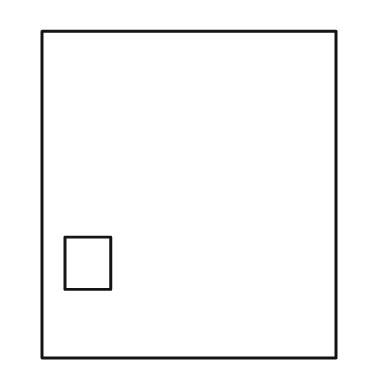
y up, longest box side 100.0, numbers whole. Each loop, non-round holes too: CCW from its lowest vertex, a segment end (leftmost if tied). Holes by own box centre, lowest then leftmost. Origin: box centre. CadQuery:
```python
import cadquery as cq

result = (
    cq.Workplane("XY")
    .moveTo(-45.0, -50.0)
    .lineTo(45.0, -50.0)
    .lineTo(45.0, 50.0)
    .lineTo(-45.0, 50.0)
    .close()
    .moveTo(-38.0, -29.0)
    .lineTo(-24.0, -29.0)
    .lineTo(-24.0, -13.0)
    .lineTo(-38.0, -13.0)
    .close()
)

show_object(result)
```